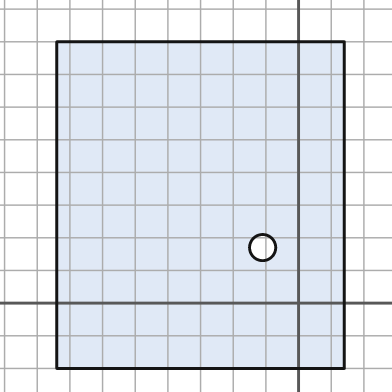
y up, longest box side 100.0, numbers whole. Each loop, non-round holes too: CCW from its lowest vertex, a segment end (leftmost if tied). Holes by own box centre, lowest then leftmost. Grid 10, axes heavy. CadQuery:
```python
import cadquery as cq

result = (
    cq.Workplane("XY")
    .moveTo(-74.0, -20.0)
    .lineTo(14.0, -20.0)
    .lineTo(14.0, 80.0)
    .lineTo(-74.0, 80.0)
    .close()
    .moveTo(-11.0, 17.0)
    .circle(4.0)
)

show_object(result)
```